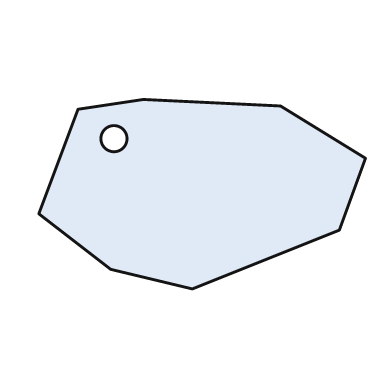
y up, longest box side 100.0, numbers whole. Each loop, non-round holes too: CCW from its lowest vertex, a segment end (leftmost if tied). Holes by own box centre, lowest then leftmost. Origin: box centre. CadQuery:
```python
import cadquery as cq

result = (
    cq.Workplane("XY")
    .moveTo(-3.0, -29.0)
    .lineTo(42.0, -11.0)
    .lineTo(50.0, 11.0)
    .lineTo(24.0, 27.0)
    .lineTo(-18.0, 29.0)
    .lineTo(-38.0, 26.0)
    .lineTo(-50.0, -6.0)
    .lineTo(-28.0, -23.0)
    .close()
    .moveTo(-27.0, 17.0)
    .circle(4.0)
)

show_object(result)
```